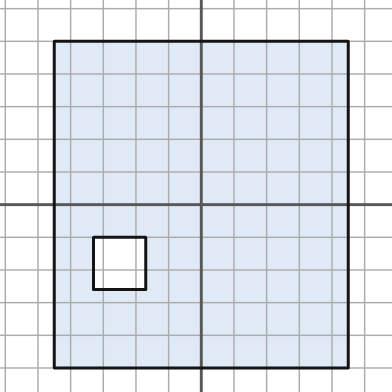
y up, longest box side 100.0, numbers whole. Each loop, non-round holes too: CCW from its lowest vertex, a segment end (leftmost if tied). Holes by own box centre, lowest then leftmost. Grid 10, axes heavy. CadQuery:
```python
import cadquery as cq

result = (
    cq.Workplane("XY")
    .moveTo(-45.0, -50.0)
    .lineTo(45.0, -50.0)
    .lineTo(45.0, 50.0)
    .lineTo(-45.0, 50.0)
    .close()
    .moveTo(-33.0, -26.0)
    .lineTo(-17.0, -26.0)
    .lineTo(-17.0, -10.0)
    .lineTo(-33.0, -10.0)
    .close()
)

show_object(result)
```